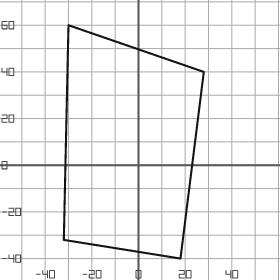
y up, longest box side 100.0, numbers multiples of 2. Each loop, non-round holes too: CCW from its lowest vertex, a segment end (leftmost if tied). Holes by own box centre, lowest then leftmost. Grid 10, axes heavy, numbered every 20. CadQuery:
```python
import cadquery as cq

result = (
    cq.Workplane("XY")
    .moveTo(18.0, -40.0)
    .lineTo(28.0, 40.0)
    .lineTo(-30.0, 60.0)
    .lineTo(-32.0, -32.0)
    .close()
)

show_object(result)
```